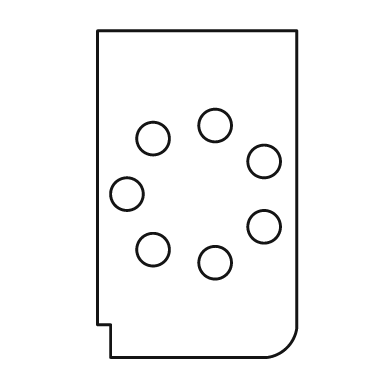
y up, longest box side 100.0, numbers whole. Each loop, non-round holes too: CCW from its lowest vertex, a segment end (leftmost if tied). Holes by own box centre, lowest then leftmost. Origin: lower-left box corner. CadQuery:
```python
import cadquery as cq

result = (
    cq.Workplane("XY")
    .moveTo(4.0, 0.0)
    .lineTo(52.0, 0.0)
    .threePointArc((58.0, 3.0), (61.0, 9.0))
    .lineTo(61.0, 100.0)
    .lineTo(0.0, 100.0)
    .lineTo(0.0, 10.0)
    .lineTo(4.0, 10.0)
    .close()
    .moveTo(36.0, 29.0)
    .circle(5.0)
    .moveTo(17.0, 33.0)
    .circle(5.0)
    .moveTo(51.0, 40.0)
    .circle(5.0)
    .moveTo(9.0, 50.0)
    .circle(5.0)
    .moveTo(51.0, 60.0)
    .circle(5.0)
    .moveTo(17.0, 67.0)
    .circle(5.0)
    .moveTo(36.0, 71.0)
    .circle(5.0)
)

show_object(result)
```